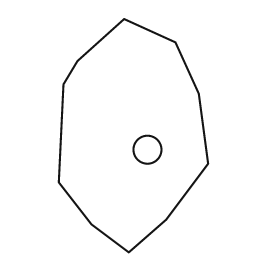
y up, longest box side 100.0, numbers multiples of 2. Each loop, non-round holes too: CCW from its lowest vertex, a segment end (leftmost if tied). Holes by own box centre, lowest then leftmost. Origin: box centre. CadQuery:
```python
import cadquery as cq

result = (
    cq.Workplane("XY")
    .moveTo(-2.0, -50.0)
    .lineTo(14.0, -36.0)
    .lineTo(32.0, -12.0)
    .lineTo(28.0, 18.0)
    .lineTo(18.0, 40.0)
    .lineTo(-4.0, 50.0)
    .lineTo(-24.0, 32.0)
    .lineTo(-30.0, 22.0)
    .lineTo(-32.0, -20.0)
    .lineTo(-18.0, -38.0)
    .close()
    .moveTo(6.0, -6.0)
    .circle(6.0)
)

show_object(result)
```